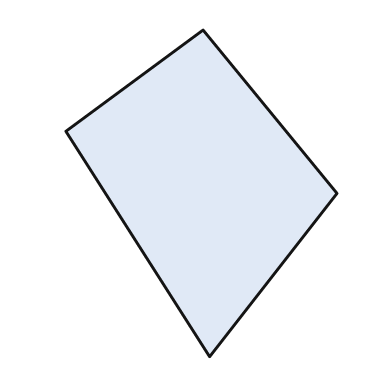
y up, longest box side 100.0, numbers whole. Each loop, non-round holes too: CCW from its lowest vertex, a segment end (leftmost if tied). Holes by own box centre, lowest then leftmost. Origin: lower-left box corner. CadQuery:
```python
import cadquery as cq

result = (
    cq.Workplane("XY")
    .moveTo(44.0, 0.0)
    .lineTo(83.0, 50.0)
    .lineTo(42.0, 100.0)
    .lineTo(0.0, 69.0)
    .close()
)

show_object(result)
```